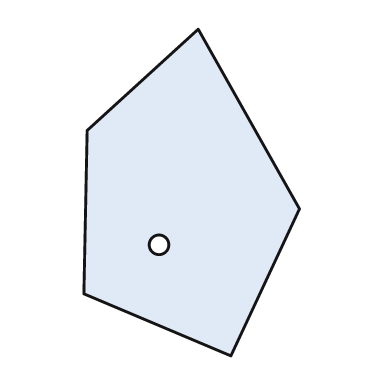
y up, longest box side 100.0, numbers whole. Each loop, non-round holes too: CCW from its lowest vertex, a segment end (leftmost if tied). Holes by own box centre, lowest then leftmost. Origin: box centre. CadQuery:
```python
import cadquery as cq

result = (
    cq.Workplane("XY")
    .moveTo(12.0, -50.0)
    .lineTo(33.0, -5.0)
    .lineTo(2.0, 50.0)
    .lineTo(-32.0, 19.0)
    .lineTo(-33.0, -31.0)
    .close()
    .moveTo(-10.0, -16.0)
    .circle(3.0)
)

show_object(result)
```